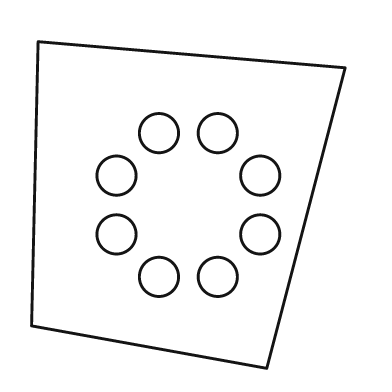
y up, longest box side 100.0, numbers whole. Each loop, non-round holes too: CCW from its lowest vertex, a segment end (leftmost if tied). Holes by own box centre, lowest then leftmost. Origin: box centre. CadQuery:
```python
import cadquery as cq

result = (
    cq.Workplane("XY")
    .moveTo(24.0, -50.0)
    .lineTo(48.0, 42.0)
    .lineTo(-46.0, 50.0)
    .lineTo(-48.0, -37.0)
    .close()
    .moveTo(-9.0, -22.0)
    .circle(6.0)
    .moveTo(9.0, -22.0)
    .circle(6.0)
    .moveTo(-22.0, -9.0)
    .circle(6.0)
    .moveTo(22.0, -9.0)
    .circle(6.0)
    .moveTo(-22.0, 9.0)
    .circle(6.0)
    .moveTo(22.0, 9.0)
    .circle(6.0)
    .moveTo(-9.0, 22.0)
    .circle(6.0)
    .moveTo(9.0, 22.0)
    .circle(6.0)
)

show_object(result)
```